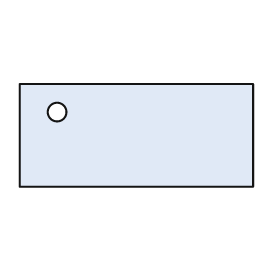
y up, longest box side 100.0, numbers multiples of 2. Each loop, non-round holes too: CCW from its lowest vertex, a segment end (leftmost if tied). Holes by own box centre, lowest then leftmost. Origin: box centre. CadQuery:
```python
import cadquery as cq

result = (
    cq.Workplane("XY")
    .moveTo(-50.0, -22.0)
    .lineTo(50.0, -22.0)
    .lineTo(50.0, 22.0)
    .lineTo(-50.0, 22.0)
    .close()
    .moveTo(-34.0, 10.0)
    .circle(4.0)
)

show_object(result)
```